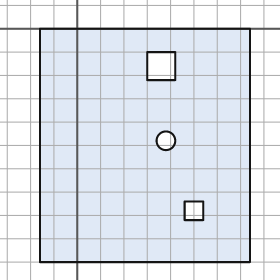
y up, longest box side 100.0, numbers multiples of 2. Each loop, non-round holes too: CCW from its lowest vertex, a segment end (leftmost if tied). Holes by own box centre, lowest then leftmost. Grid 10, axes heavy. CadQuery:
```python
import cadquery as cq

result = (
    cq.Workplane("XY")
    .moveTo(-16.0, -100.0)
    .lineTo(74.0, -100.0)
    .lineTo(74.0, 0.0)
    .lineTo(-16.0, 0.0)
    .close()
    .moveTo(46.0, -82.0)
    .lineTo(54.0, -82.0)
    .lineTo(54.0, -74.0)
    .lineTo(46.0, -74.0)
    .close()
    .moveTo(38.0, -48.0)
    .circle(4.0)
    .moveTo(30.0, -22.0)
    .lineTo(42.0, -22.0)
    .lineTo(42.0, -10.0)
    .lineTo(30.0, -10.0)
    .close()
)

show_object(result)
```